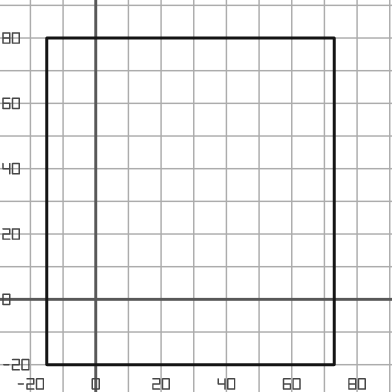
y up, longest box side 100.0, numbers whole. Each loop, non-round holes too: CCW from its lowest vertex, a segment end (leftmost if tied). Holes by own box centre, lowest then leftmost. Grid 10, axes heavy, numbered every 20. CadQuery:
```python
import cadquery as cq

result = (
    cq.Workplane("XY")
    .moveTo(-15.0, -20.0)
    .lineTo(73.0, -20.0)
    .lineTo(73.0, 80.0)
    .lineTo(-15.0, 80.0)
    .close()
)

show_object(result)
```